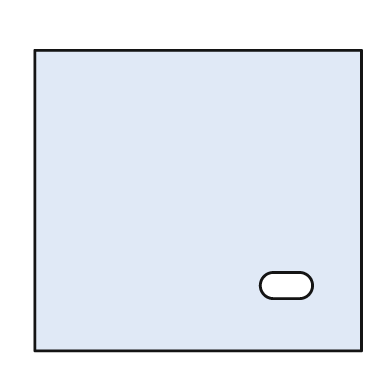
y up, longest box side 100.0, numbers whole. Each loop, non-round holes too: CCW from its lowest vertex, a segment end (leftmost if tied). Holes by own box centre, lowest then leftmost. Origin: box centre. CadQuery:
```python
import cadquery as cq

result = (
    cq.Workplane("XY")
    .moveTo(-50.0, -46.0)
    .lineTo(50.0, -46.0)
    .lineTo(50.0, 46.0)
    .lineTo(-50.0, 46.0)
    .close()
    .moveTo(23.0, -30.0)
    .lineTo(31.0, -30.0)
    .threePointArc((35.0, -26.0), (31.0, -22.0))
    .lineTo(23.0, -22.0)
    .threePointArc((19.0, -26.0), (23.0, -30.0))
    .close()
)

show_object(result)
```